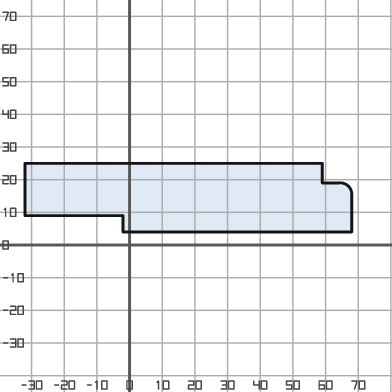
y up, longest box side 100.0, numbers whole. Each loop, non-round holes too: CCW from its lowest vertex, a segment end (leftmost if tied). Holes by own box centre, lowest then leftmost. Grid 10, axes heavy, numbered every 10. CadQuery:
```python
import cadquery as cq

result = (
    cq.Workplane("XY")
    .moveTo(-2.0, 4.0)
    .lineTo(68.0, 4.0)
    .lineTo(68.0, 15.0)
    .threePointArc((67.0, 18.0), (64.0, 19.0))
    .lineTo(59.0, 19.0)
    .lineTo(59.0, 25.0)
    .lineTo(-32.0, 25.0)
    .lineTo(-32.0, 9.0)
    .lineTo(-2.0, 9.0)
    .close()
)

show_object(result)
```